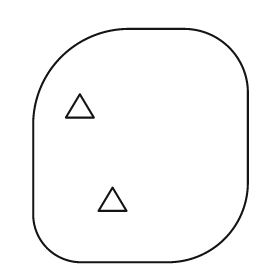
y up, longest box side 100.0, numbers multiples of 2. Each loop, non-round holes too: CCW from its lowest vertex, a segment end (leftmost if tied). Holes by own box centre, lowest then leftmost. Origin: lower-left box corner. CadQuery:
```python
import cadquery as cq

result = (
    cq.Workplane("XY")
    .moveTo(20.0, 0.0)
    .lineTo(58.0, 0.0)
    .threePointArc((82.0, 10.0), (92.0, 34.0))
    .lineTo(92.0, 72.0)
    .threePointArc((84.0, 92.0), (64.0, 100.0))
    .lineTo(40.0, 100.0)
    .threePointArc((12.0, 88.0), (0.0, 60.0))
    .lineTo(0.0, 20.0)
    .threePointArc((6.0, 6.0), (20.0, 0.0))
    .close()
    .moveTo(28.0, 22.0)
    .lineTo(40.0, 22.0)
    .lineTo(34.0, 32.0)
    .close()
    .moveTo(14.0, 62.0)
    .lineTo(26.0, 62.0)
    .lineTo(20.0, 72.0)
    .close()
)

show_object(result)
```